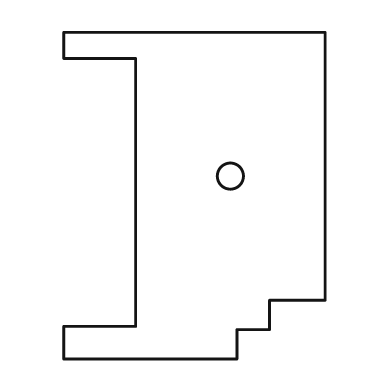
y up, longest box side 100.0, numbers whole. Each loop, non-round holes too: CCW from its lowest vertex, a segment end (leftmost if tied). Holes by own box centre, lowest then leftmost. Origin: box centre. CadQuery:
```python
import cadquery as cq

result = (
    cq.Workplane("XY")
    .moveTo(-40.0, -50.0)
    .lineTo(13.0, -50.0)
    .lineTo(13.0, -41.0)
    .lineTo(23.0, -41.0)
    .lineTo(23.0, -32.0)
    .lineTo(40.0, -32.0)
    .lineTo(40.0, 50.0)
    .lineTo(-40.0, 50.0)
    .lineTo(-40.0, 42.0)
    .lineTo(-18.0, 42.0)
    .lineTo(-18.0, -40.0)
    .lineTo(-40.0, -40.0)
    .close()
    .moveTo(11.0, 6.0)
    .circle(4.0)
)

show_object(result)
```